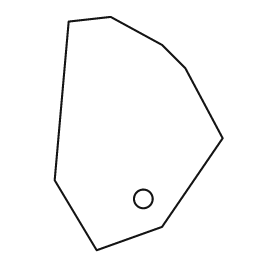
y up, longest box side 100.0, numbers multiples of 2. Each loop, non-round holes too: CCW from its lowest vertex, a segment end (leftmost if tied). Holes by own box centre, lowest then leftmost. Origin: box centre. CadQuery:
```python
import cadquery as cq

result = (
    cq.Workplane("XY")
    .moveTo(-18.0, -50.0)
    .lineTo(10.0, -40.0)
    .lineTo(36.0, -2.0)
    .lineTo(20.0, 28.0)
    .lineTo(10.0, 38.0)
    .lineTo(-12.0, 50.0)
    .lineTo(-30.0, 48.0)
    .lineTo(-36.0, -20.0)
    .close()
    .moveTo(2.0, -28.0)
    .circle(4.0)
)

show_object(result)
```